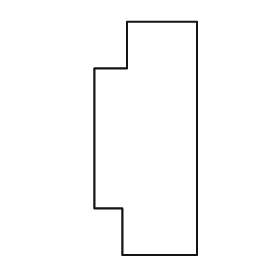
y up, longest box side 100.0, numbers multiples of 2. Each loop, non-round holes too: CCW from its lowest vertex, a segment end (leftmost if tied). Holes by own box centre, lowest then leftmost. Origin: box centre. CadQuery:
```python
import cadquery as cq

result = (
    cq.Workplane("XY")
    .moveTo(-10.0, -50.0)
    .lineTo(22.0, -50.0)
    .lineTo(22.0, 50.0)
    .lineTo(-8.0, 50.0)
    .lineTo(-8.0, 30.0)
    .lineTo(-22.0, 30.0)
    .lineTo(-22.0, -30.0)
    .lineTo(-10.0, -30.0)
    .close()
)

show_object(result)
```